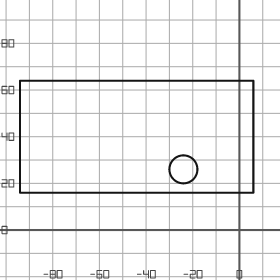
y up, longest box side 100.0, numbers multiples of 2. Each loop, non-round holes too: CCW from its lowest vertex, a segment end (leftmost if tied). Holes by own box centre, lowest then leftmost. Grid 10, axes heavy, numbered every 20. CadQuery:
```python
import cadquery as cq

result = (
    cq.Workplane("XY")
    .moveTo(-94.0, 16.0)
    .lineTo(6.0, 16.0)
    .lineTo(6.0, 64.0)
    .lineTo(-94.0, 64.0)
    .close()
    .moveTo(-24.0, 26.0)
    .circle(6.0)
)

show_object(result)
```